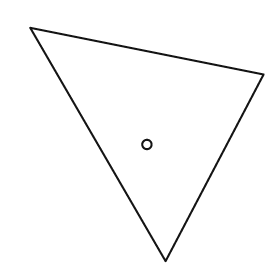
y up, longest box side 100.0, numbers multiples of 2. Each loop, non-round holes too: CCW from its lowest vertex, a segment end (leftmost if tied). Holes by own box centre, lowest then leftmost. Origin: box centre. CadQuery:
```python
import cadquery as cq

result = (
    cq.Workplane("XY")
    .moveTo(8.0, -50.0)
    .lineTo(50.0, 30.0)
    .lineTo(-50.0, 50.0)
    .close()
    .moveTo(0.0, 0.0)
    .circle(2.0)
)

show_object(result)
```